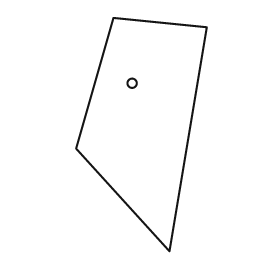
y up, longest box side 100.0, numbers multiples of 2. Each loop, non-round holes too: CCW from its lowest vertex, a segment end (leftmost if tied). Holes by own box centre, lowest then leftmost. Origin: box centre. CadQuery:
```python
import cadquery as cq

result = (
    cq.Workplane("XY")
    .moveTo(12.0, -50.0)
    .lineTo(28.0, 46.0)
    .lineTo(-12.0, 50.0)
    .lineTo(-28.0, -6.0)
    .close()
    .moveTo(-4.0, 22.0)
    .circle(2.0)
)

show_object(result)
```